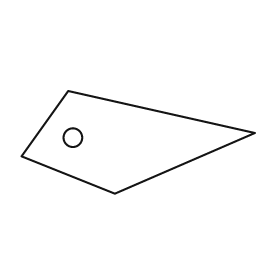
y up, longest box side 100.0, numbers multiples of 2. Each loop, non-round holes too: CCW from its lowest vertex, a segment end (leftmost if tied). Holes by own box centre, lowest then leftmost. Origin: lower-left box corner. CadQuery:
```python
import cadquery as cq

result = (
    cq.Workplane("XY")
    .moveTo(40.0, 0.0)
    .lineTo(100.0, 26.0)
    .lineTo(20.0, 44.0)
    .lineTo(0.0, 16.0)
    .close()
    .moveTo(22.0, 24.0)
    .circle(4.0)
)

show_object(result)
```